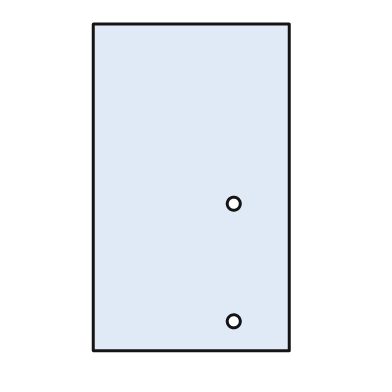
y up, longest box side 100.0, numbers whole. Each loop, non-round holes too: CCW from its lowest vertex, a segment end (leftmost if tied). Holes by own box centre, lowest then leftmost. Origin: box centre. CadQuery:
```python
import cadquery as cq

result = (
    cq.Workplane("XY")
    .moveTo(-30.0, -50.0)
    .lineTo(30.0, -50.0)
    .lineTo(30.0, 50.0)
    .lineTo(-30.0, 50.0)
    .close()
    .moveTo(13.0, -41.0)
    .circle(2.0)
    .moveTo(13.0, -5.0)
    .circle(2.0)
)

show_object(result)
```